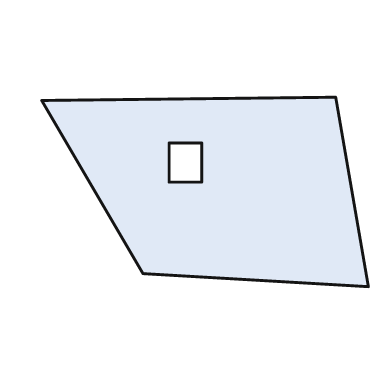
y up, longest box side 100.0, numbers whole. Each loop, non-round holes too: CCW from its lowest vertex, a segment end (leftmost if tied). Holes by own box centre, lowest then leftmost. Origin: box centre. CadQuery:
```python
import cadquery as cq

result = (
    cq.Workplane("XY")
    .moveTo(50.0, -29.0)
    .lineTo(40.0, 29.0)
    .lineTo(-50.0, 28.0)
    .lineTo(-19.0, -25.0)
    .close()
    .moveTo(-11.0, 3.0)
    .lineTo(-1.0, 3.0)
    .lineTo(-1.0, 15.0)
    .lineTo(-11.0, 15.0)
    .close()
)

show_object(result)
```